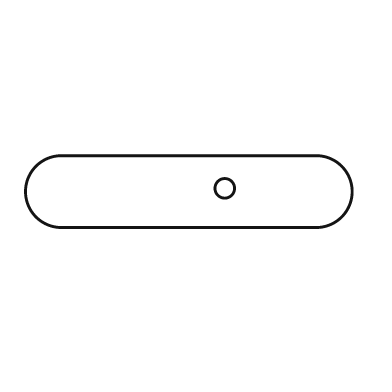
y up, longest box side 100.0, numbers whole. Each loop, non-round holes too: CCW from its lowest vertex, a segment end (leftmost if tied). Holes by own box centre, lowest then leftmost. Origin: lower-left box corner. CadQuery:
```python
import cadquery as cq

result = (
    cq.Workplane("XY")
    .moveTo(11.0, 0.0)
    .lineTo(89.0, 0.0)
    .threePointArc((100.0, 11.0), (89.0, 22.0))
    .lineTo(11.0, 22.0)
    .threePointArc((0.0, 11.0), (11.0, 0.0))
    .close()
    .moveTo(61.0, 12.0)
    .circle(3.0)
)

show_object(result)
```